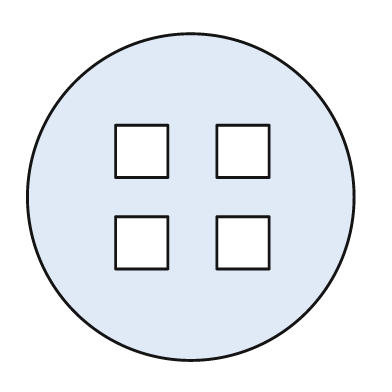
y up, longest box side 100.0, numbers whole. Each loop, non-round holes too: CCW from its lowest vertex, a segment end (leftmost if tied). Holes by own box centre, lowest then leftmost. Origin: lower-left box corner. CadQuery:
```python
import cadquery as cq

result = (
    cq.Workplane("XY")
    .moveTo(50.0, 50.0)
    .circle(50.0)
    .moveTo(27.0, 28.0)
    .lineTo(43.0, 28.0)
    .lineTo(43.0, 44.0)
    .lineTo(27.0, 44.0)
    .close()
    .moveTo(58.0, 28.0)
    .lineTo(74.0, 28.0)
    .lineTo(74.0, 44.0)
    .lineTo(58.0, 44.0)
    .close()
    .moveTo(27.0, 56.0)
    .lineTo(43.0, 56.0)
    .lineTo(43.0, 72.0)
    .lineTo(27.0, 72.0)
    .close()
    .moveTo(58.0, 56.0)
    .lineTo(74.0, 56.0)
    .lineTo(74.0, 72.0)
    .lineTo(58.0, 72.0)
    .close()
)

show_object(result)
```